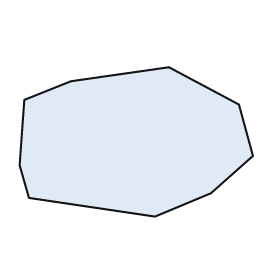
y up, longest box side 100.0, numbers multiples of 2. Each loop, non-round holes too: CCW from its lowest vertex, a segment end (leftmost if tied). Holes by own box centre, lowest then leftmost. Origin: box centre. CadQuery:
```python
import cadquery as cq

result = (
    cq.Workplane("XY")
    .moveTo(8.0, -32.0)
    .lineTo(32.0, -22.0)
    .lineTo(50.0, -6.0)
    .lineTo(44.0, 16.0)
    .lineTo(14.0, 32.0)
    .lineTo(-28.0, 26.0)
    .lineTo(-48.0, 18.0)
    .lineTo(-50.0, -10.0)
    .lineTo(-46.0, -24.0)
    .close()
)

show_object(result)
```